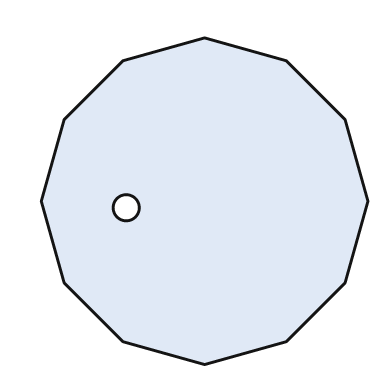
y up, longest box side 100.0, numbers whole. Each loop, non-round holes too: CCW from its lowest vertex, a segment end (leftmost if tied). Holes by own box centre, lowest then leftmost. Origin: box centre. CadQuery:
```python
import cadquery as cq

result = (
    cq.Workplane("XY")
    .moveTo(0.0, -50.0)
    .lineTo(25.0, -43.0)
    .lineTo(43.0, -25.0)
    .lineTo(50.0, 0.0)
    .lineTo(43.0, 25.0)
    .lineTo(25.0, 43.0)
    .lineTo(0.0, 50.0)
    .lineTo(-25.0, 43.0)
    .lineTo(-43.0, 25.0)
    .lineTo(-50.0, 0.0)
    .lineTo(-43.0, -25.0)
    .lineTo(-25.0, -43.0)
    .close()
    .moveTo(-24.0, -2.0)
    .circle(4.0)
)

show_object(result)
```